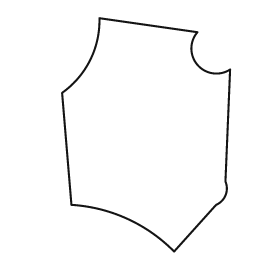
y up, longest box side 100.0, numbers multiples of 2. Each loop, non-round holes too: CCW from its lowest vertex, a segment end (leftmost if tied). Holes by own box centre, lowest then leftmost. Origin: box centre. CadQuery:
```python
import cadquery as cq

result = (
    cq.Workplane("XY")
    .moveTo(12.0, -50.0)
    .lineTo(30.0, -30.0)
    .threePointArc((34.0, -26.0), (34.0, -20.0))
    .lineTo(36.0, 28.0)
    .threePointArc((22.0, 30.0), (22.0, 44.0))
    .lineTo(-20.0, 50.0)
    .threePointArc((-24.0, 32.0), (-36.0, 18.0))
    .lineTo(-32.0, -30.0)
    .threePointArc((-8.0, -36.0), (12.0, -50.0))
    .close()
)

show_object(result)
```